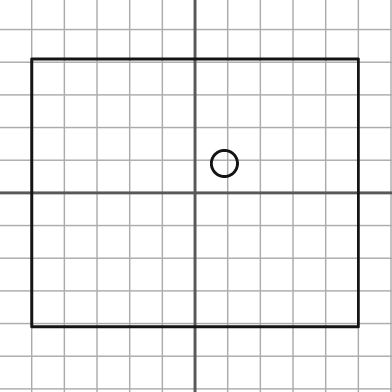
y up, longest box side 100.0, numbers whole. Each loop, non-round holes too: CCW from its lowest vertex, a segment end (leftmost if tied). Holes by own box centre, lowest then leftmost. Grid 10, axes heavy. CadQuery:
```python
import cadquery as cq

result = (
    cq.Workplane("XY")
    .moveTo(-50.0, -41.0)
    .lineTo(50.0, -41.0)
    .lineTo(50.0, 41.0)
    .lineTo(-50.0, 41.0)
    .close()
    .moveTo(9.0, 9.0)
    .circle(4.0)
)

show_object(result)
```